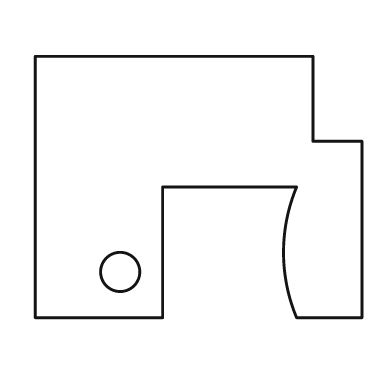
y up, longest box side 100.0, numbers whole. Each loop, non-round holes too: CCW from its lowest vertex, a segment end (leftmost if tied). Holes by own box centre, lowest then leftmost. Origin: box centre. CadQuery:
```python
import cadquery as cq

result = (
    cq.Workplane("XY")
    .moveTo(-50.0, -40.0)
    .lineTo(-11.0, -40.0)
    .lineTo(-11.0, 0.0)
    .lineTo(30.0, 0.0)
    .threePointArc((26.0, -20.0), (30.0, -40.0))
    .lineTo(50.0, -40.0)
    .lineTo(50.0, 14.0)
    .lineTo(35.0, 14.0)
    .lineTo(35.0, 40.0)
    .lineTo(-50.0, 40.0)
    .close()
    .moveTo(-24.0, -26.0)
    .circle(6.0)
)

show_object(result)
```